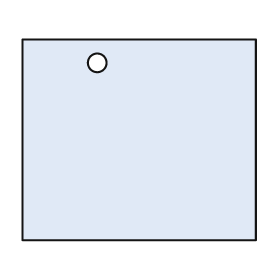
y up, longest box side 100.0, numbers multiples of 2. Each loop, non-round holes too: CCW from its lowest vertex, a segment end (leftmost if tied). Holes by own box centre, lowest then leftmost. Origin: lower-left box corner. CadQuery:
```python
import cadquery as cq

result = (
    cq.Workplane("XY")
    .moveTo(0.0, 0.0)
    .lineTo(100.0, 0.0)
    .lineTo(100.0, 86.0)
    .lineTo(0.0, 86.0)
    .close()
    .moveTo(32.0, 76.0)
    .circle(4.0)
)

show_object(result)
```